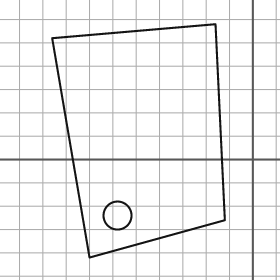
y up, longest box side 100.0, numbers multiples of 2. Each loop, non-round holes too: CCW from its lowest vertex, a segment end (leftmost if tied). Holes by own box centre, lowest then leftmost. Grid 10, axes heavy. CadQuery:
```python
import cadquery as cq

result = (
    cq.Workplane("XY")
    .moveTo(-70.0, -42.0)
    .lineTo(-12.0, -26.0)
    .lineTo(-16.0, 58.0)
    .lineTo(-86.0, 52.0)
    .close()
    .moveTo(-58.0, -24.0)
    .circle(6.0)
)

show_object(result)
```